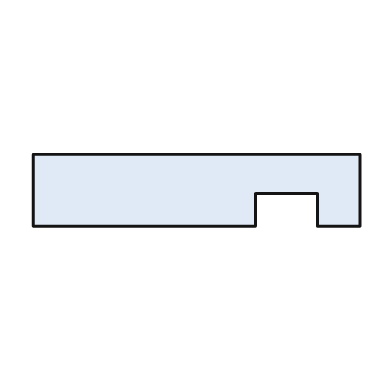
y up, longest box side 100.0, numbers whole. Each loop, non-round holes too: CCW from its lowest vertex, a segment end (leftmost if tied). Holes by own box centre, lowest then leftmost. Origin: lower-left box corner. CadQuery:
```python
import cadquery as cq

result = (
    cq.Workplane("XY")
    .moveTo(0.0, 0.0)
    .lineTo(68.0, 0.0)
    .lineTo(68.0, 10.0)
    .lineTo(87.0, 10.0)
    .lineTo(87.0, 0.0)
    .lineTo(100.0, 0.0)
    .lineTo(100.0, 22.0)
    .lineTo(0.0, 22.0)
    .close()
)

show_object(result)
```